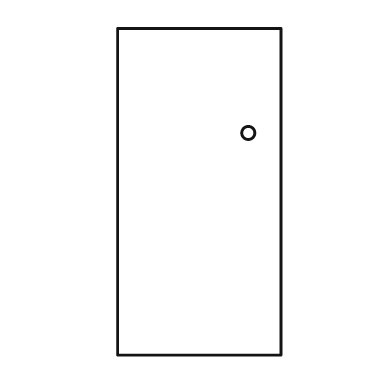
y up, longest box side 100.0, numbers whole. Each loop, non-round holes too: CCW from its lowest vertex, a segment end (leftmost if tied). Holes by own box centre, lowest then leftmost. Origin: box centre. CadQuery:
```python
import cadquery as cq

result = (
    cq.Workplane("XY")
    .moveTo(-25.0, -50.0)
    .lineTo(25.0, -50.0)
    .lineTo(25.0, 50.0)
    .lineTo(-25.0, 50.0)
    .close()
    .moveTo(15.0, 18.0)
    .circle(2.0)
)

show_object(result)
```